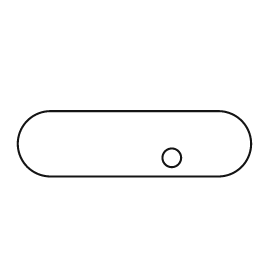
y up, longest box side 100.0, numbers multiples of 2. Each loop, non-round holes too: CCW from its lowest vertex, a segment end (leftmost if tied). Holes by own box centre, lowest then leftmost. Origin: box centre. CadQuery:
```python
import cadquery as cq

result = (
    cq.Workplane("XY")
    .moveTo(-36.0, -14.0)
    .lineTo(36.0, -14.0)
    .threePointArc((50.0, 0.0), (36.0, 14.0))
    .lineTo(-36.0, 14.0)
    .threePointArc((-50.0, 0.0), (-36.0, -14.0))
    .close()
    .moveTo(16.0, -6.0)
    .circle(4.0)
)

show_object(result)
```